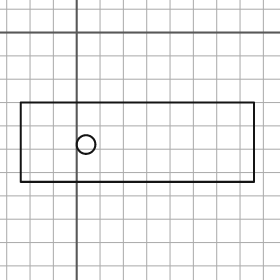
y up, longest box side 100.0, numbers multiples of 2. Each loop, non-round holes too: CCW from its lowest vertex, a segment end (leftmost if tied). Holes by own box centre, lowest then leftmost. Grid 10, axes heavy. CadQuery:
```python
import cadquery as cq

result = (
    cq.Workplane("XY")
    .moveTo(-24.0, -64.0)
    .lineTo(76.0, -64.0)
    .lineTo(76.0, -30.0)
    .lineTo(-24.0, -30.0)
    .close()
    .moveTo(4.0, -48.0)
    .circle(4.0)
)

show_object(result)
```